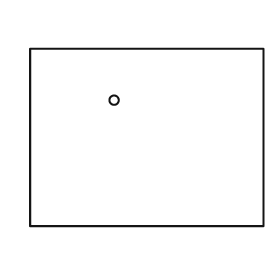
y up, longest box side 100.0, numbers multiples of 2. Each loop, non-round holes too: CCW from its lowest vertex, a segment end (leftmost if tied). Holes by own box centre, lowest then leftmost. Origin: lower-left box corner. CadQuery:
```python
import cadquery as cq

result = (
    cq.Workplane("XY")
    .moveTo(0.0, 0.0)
    .lineTo(100.0, 0.0)
    .lineTo(100.0, 76.0)
    .lineTo(0.0, 76.0)
    .close()
    .moveTo(36.0, 54.0)
    .circle(2.0)
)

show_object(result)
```